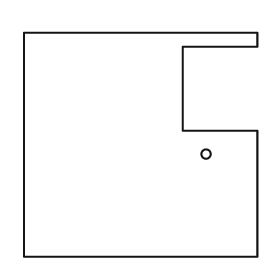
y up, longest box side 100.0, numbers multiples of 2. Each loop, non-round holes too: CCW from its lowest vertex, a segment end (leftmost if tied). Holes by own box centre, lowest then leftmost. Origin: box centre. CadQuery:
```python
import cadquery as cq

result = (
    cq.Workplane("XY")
    .moveTo(-50.0, -48.0)
    .lineTo(50.0, -48.0)
    .lineTo(50.0, 6.0)
    .lineTo(18.0, 6.0)
    .lineTo(18.0, 42.0)
    .lineTo(50.0, 42.0)
    .lineTo(50.0, 48.0)
    .lineTo(-50.0, 48.0)
    .close()
    .moveTo(28.0, -4.0)
    .circle(2.0)
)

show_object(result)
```